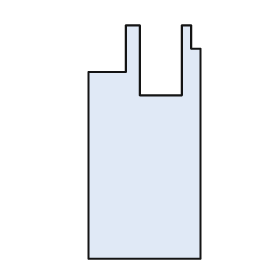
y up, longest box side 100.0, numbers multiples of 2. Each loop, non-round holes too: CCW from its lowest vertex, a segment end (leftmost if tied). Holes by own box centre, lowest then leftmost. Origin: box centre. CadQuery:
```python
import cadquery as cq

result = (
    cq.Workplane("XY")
    .moveTo(-24.0, -50.0)
    .lineTo(24.0, -50.0)
    .lineTo(24.0, 40.0)
    .lineTo(20.0, 40.0)
    .lineTo(20.0, 50.0)
    .lineTo(16.0, 50.0)
    .lineTo(16.0, 20.0)
    .lineTo(-2.0, 20.0)
    .lineTo(-2.0, 50.0)
    .lineTo(-8.0, 50.0)
    .lineTo(-8.0, 30.0)
    .lineTo(-24.0, 30.0)
    .close()
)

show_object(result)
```